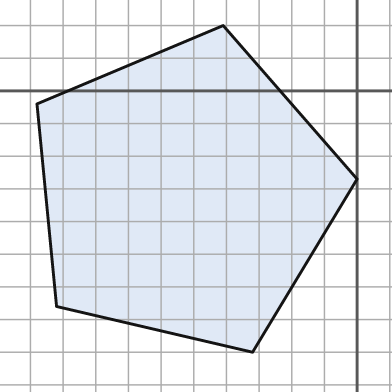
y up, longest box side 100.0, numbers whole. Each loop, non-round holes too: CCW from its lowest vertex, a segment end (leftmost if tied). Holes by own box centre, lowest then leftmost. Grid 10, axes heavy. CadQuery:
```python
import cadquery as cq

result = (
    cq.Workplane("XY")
    .moveTo(-32.0, -80.0)
    .lineTo(0.0, -27.0)
    .lineTo(-41.0, 20.0)
    .lineTo(-98.0, -4.0)
    .lineTo(-92.0, -66.0)
    .close()
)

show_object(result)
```